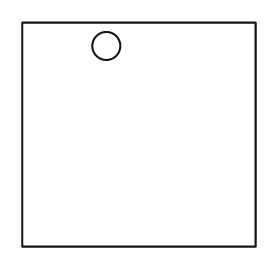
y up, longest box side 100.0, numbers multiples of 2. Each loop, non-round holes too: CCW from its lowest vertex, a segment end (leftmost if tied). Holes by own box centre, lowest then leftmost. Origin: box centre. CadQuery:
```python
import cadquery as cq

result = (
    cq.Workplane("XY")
    .moveTo(-50.0, -48.0)
    .lineTo(50.0, -48.0)
    .lineTo(50.0, 48.0)
    .lineTo(-50.0, 48.0)
    .close()
    .moveTo(-14.0, 38.0)
    .circle(6.0)
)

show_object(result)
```